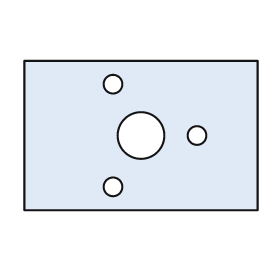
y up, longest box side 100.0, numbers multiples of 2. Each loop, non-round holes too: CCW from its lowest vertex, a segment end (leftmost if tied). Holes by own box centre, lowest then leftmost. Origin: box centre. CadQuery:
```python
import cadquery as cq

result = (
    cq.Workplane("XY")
    .moveTo(-50.0, -32.0)
    .lineTo(50.0, -32.0)
    .lineTo(50.0, 32.0)
    .lineTo(-50.0, 32.0)
    .close()
    .moveTo(-12.0, -22.0)
    .circle(4.0)
    .moveTo(0.0, 0.0)
    .circle(10.0)
    .moveTo(24.0, 0.0)
    .circle(4.0)
    .moveTo(-12.0, 22.0)
    .circle(4.0)
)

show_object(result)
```